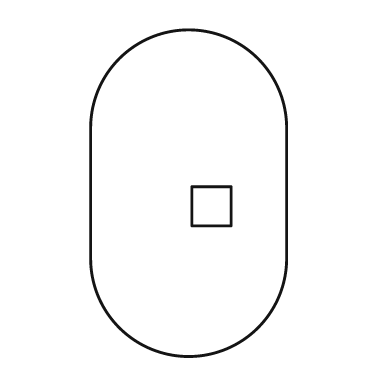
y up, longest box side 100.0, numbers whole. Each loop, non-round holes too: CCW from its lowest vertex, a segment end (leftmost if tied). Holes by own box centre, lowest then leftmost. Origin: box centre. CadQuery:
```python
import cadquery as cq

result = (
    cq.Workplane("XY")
    .moveTo(-30.0, -20.0)
    .threePointArc((0.0, -50.0), (30.0, -20.0))
    .lineTo(30.0, 20.0)
    .threePointArc((0.0, 50.0), (-30.0, 20.0))
    .close()
    .moveTo(1.0, -10.0)
    .lineTo(13.0, -10.0)
    .lineTo(13.0, 2.0)
    .lineTo(1.0, 2.0)
    .close()
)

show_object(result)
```